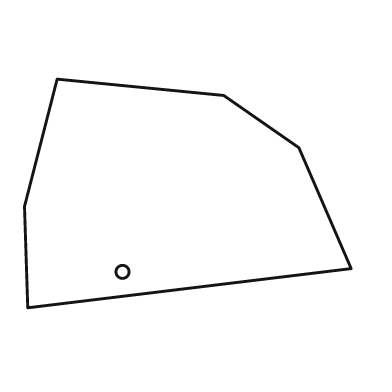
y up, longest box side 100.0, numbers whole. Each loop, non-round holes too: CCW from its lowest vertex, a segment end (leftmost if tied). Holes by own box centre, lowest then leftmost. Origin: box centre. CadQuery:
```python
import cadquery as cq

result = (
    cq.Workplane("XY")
    .moveTo(-49.0, -35.0)
    .lineTo(50.0, -23.0)
    .lineTo(34.0, 14.0)
    .lineTo(11.0, 30.0)
    .lineTo(-40.0, 35.0)
    .lineTo(-50.0, -4.0)
    .close()
    .moveTo(-20.0, -24.0)
    .circle(2.0)
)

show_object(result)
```